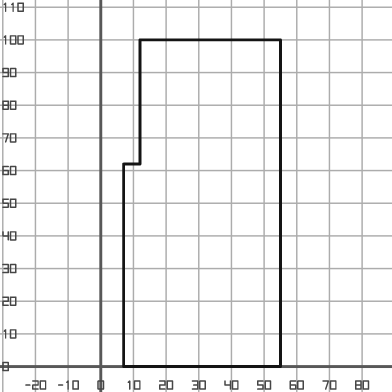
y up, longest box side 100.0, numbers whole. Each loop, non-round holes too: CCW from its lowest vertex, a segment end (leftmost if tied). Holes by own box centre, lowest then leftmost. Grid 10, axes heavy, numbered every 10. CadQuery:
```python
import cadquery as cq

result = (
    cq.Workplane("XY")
    .moveTo(7.0, 0.0)
    .lineTo(55.0, 0.0)
    .lineTo(55.0, 100.0)
    .lineTo(12.0, 100.0)
    .lineTo(12.0, 62.0)
    .lineTo(7.0, 62.0)
    .close()
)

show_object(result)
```